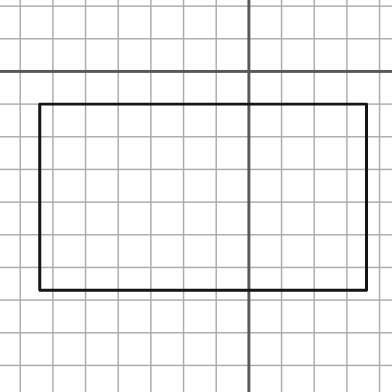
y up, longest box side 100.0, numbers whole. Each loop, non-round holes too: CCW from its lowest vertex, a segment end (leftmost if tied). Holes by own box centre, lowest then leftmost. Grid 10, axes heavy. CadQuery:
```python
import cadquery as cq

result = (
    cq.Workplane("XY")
    .moveTo(-64.0, -67.0)
    .lineTo(36.0, -67.0)
    .lineTo(36.0, -10.0)
    .lineTo(-64.0, -10.0)
    .close()
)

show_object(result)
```